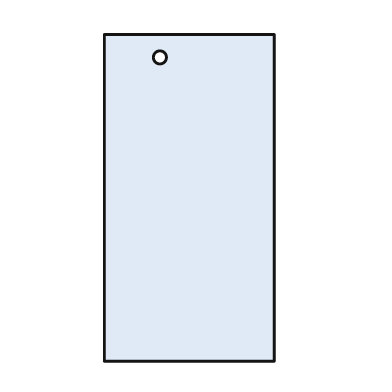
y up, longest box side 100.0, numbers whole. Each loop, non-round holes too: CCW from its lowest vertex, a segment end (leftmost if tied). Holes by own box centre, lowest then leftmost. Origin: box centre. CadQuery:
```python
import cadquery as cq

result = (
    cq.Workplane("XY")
    .moveTo(-26.0, -50.0)
    .lineTo(26.0, -50.0)
    .lineTo(26.0, 50.0)
    .lineTo(-26.0, 50.0)
    .close()
    .moveTo(-9.0, 43.0)
    .circle(2.0)
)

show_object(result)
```